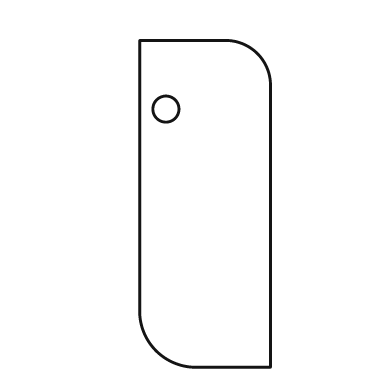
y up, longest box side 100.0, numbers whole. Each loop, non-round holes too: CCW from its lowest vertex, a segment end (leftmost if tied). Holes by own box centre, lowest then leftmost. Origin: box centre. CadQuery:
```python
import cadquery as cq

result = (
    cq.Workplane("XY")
    .moveTo(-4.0, -50.0)
    .lineTo(20.0, -50.0)
    .lineTo(20.0, 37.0)
    .threePointArc((16.0, 46.0), (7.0, 50.0))
    .lineTo(-20.0, 50.0)
    .lineTo(-20.0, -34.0)
    .threePointArc((-15.0, -45.0), (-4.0, -50.0))
    .close()
    .moveTo(-12.0, 29.0)
    .circle(4.0)
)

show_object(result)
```